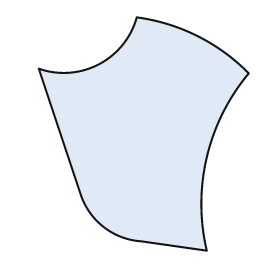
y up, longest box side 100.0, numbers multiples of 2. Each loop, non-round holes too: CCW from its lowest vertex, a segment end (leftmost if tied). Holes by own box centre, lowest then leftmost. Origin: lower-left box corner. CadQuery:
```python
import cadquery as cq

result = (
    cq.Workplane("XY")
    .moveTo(72.0, 0.0)
    .threePointArc((72.0, 40.0), (90.0, 76.0))
    .threePointArc((68.0, 92.0), (42.0, 100.0))
    .threePointArc((26.0, 80.0), (0.0, 78.0))
    .lineTo(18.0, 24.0)
    .threePointArc((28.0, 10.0), (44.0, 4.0))
    .close()
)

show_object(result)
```